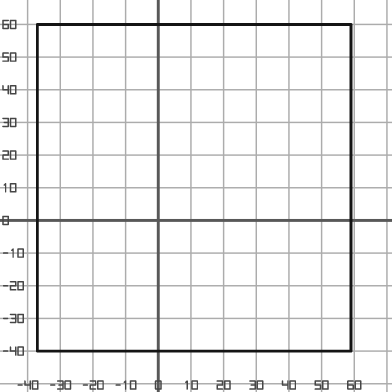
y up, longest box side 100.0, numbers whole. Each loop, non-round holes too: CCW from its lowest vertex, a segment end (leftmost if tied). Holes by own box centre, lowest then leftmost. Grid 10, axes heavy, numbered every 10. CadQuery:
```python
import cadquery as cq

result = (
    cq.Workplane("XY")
    .moveTo(-37.0, -40.0)
    .lineTo(59.0, -40.0)
    .lineTo(59.0, 60.0)
    .lineTo(-37.0, 60.0)
    .close()
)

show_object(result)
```